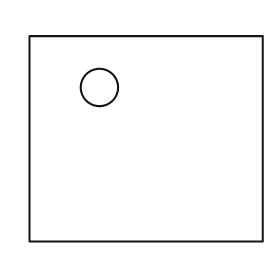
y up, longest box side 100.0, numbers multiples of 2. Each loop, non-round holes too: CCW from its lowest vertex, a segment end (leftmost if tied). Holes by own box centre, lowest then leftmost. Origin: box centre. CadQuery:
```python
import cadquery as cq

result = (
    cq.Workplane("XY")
    .moveTo(-50.0, -44.0)
    .lineTo(50.0, -44.0)
    .lineTo(50.0, 44.0)
    .lineTo(-50.0, 44.0)
    .close()
    .moveTo(-20.0, 22.0)
    .circle(8.0)
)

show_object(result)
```